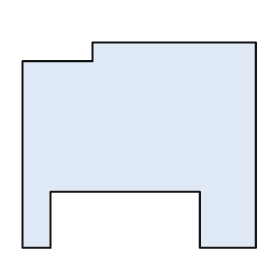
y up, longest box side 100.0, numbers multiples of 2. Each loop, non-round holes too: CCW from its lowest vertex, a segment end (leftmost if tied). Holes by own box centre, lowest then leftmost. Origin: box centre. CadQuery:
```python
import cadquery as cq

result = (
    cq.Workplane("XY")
    .moveTo(-50.0, -44.0)
    .lineTo(-38.0, -44.0)
    .lineTo(-38.0, -20.0)
    .lineTo(26.0, -20.0)
    .lineTo(26.0, -44.0)
    .lineTo(50.0, -44.0)
    .lineTo(50.0, 44.0)
    .lineTo(-20.0, 44.0)
    .lineTo(-20.0, 36.0)
    .lineTo(-50.0, 36.0)
    .close()
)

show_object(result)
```